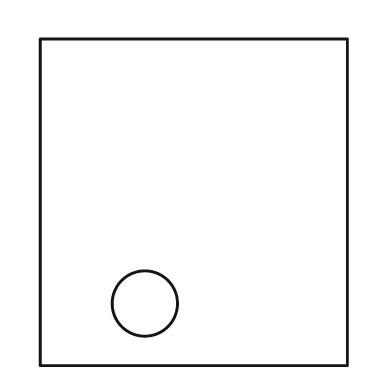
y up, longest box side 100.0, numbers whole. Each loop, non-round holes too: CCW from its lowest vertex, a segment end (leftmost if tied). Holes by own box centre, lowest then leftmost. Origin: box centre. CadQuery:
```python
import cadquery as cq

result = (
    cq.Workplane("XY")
    .moveTo(-47.0, -50.0)
    .lineTo(47.0, -50.0)
    .lineTo(47.0, 50.0)
    .lineTo(-47.0, 50.0)
    .close()
    .moveTo(-15.0, -31.0)
    .circle(10.0)
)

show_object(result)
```